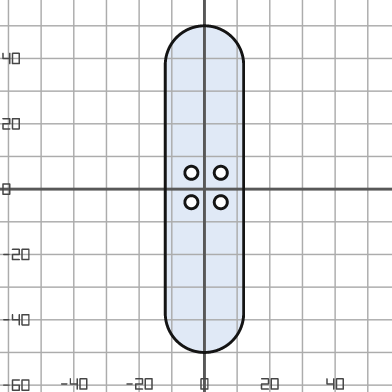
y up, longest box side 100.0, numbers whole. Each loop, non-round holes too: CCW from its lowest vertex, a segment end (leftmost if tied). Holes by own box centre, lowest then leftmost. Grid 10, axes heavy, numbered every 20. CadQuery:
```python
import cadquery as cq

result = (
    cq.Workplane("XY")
    .moveTo(-12.0, -38.0)
    .threePointArc((0.0, -50.0), (12.0, -38.0))
    .lineTo(12.0, 38.0)
    .threePointArc((0.0, 50.0), (-12.0, 38.0))
    .close()
    .moveTo(-4.0, -4.0)
    .circle(2.0)
    .moveTo(5.0, -4.0)
    .circle(2.0)
    .moveTo(-4.0, 5.0)
    .circle(2.0)
    .moveTo(5.0, 5.0)
    .circle(2.0)
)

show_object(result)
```